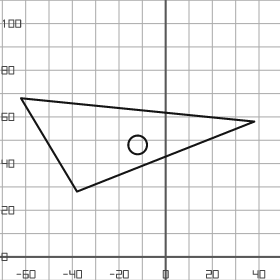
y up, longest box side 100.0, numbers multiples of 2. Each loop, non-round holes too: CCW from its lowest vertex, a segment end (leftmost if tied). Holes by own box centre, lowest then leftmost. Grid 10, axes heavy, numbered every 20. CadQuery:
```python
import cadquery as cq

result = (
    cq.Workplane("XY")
    .moveTo(-38.0, 28.0)
    .lineTo(38.0, 58.0)
    .lineTo(-62.0, 68.0)
    .close()
    .moveTo(-12.0, 48.0)
    .circle(4.0)
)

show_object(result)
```